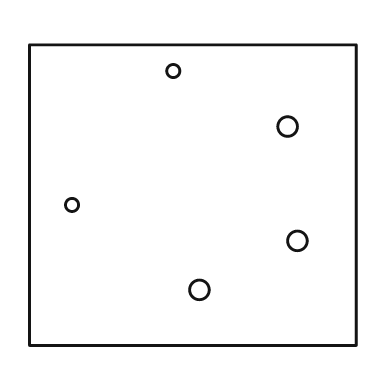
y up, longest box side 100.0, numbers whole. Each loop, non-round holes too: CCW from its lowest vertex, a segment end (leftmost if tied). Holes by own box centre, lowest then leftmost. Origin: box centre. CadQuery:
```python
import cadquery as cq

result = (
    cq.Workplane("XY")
    .moveTo(-50.0, -46.0)
    .lineTo(50.0, -46.0)
    .lineTo(50.0, 46.0)
    .lineTo(-50.0, 46.0)
    .close()
    .moveTo(2.0, -29.0)
    .circle(3.0)
    .moveTo(32.0, -14.0)
    .circle(3.0)
    .moveTo(-37.0, -3.0)
    .circle(2.0)
    .moveTo(29.0, 21.0)
    .circle(3.0)
    .moveTo(-6.0, 38.0)
    .circle(2.0)
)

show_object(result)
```